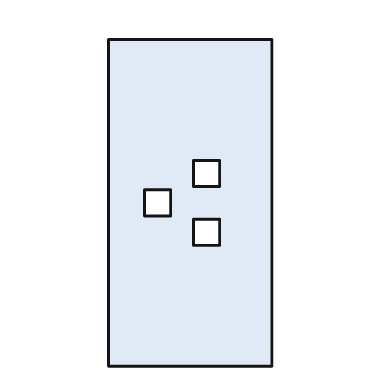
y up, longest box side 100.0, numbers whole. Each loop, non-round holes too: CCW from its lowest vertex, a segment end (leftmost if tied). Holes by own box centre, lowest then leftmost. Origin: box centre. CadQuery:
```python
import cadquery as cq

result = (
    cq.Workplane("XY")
    .moveTo(-25.0, -50.0)
    .lineTo(25.0, -50.0)
    .lineTo(25.0, 50.0)
    .lineTo(-25.0, 50.0)
    .close()
    .moveTo(1.0, -13.0)
    .lineTo(9.0, -13.0)
    .lineTo(9.0, -5.0)
    .lineTo(1.0, -5.0)
    .close()
    .moveTo(-14.0, -4.0)
    .lineTo(-6.0, -4.0)
    .lineTo(-6.0, 4.0)
    .lineTo(-14.0, 4.0)
    .close()
    .moveTo(1.0, 5.0)
    .lineTo(9.0, 5.0)
    .lineTo(9.0, 13.0)
    .lineTo(1.0, 13.0)
    .close()
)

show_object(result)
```